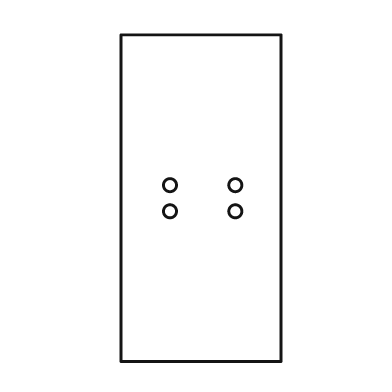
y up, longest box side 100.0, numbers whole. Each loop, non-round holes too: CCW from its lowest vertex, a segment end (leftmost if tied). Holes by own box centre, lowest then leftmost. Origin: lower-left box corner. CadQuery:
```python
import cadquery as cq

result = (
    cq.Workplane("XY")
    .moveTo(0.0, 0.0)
    .lineTo(49.0, 0.0)
    .lineTo(49.0, 100.0)
    .lineTo(0.0, 100.0)
    .close()
    .moveTo(15.0, 46.0)
    .circle(2.0)
    .moveTo(35.0, 46.0)
    .circle(2.0)
    .moveTo(15.0, 54.0)
    .circle(2.0)
    .moveTo(35.0, 54.0)
    .circle(2.0)
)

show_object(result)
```